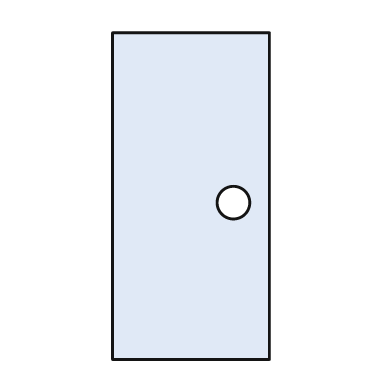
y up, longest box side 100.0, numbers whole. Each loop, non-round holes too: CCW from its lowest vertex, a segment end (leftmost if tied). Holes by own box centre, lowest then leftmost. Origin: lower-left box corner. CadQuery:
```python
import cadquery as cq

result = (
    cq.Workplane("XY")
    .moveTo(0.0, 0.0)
    .lineTo(48.0, 0.0)
    .lineTo(48.0, 100.0)
    .lineTo(0.0, 100.0)
    .close()
    .moveTo(37.0, 48.0)
    .circle(5.0)
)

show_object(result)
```